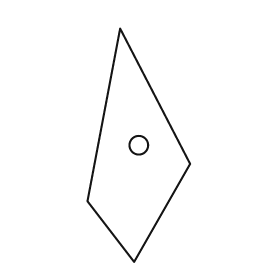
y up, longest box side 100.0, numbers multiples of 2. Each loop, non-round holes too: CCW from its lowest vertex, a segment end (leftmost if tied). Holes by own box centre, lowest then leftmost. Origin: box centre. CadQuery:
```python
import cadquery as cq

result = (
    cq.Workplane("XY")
    .moveTo(-2.0, -50.0)
    .lineTo(22.0, -8.0)
    .lineTo(-8.0, 50.0)
    .lineTo(-22.0, -24.0)
    .close()
    .moveTo(0.0, 0.0)
    .circle(4.0)
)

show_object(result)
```